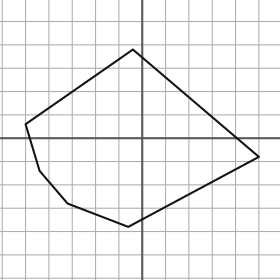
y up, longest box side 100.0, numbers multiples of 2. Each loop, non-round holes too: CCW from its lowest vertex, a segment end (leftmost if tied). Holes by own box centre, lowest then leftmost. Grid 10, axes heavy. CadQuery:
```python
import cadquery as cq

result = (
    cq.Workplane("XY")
    .moveTo(-6.0, -38.0)
    .lineTo(50.0, -8.0)
    .lineTo(-4.0, 38.0)
    .lineTo(-50.0, 6.0)
    .lineTo(-44.0, -14.0)
    .lineTo(-32.0, -28.0)
    .close()
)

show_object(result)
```